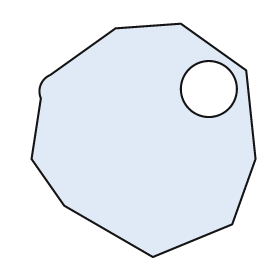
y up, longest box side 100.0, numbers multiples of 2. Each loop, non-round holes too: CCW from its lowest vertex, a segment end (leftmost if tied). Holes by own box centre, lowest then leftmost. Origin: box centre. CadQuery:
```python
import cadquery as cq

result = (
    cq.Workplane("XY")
    .moveTo(4.0, -50.0)
    .lineTo(38.0, -36.0)
    .lineTo(48.0, -8.0)
    .lineTo(44.0, 30.0)
    .lineTo(16.0, 50.0)
    .lineTo(-12.0, 48.0)
    .lineTo(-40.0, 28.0)
    .threePointArc((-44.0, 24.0), (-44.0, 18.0))
    .lineTo(-48.0, -8.0)
    .lineTo(-34.0, -28.0)
    .close()
    .moveTo(28.0, 22.0)
    .circle(12.0)
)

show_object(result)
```